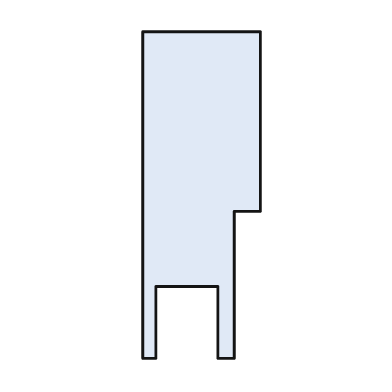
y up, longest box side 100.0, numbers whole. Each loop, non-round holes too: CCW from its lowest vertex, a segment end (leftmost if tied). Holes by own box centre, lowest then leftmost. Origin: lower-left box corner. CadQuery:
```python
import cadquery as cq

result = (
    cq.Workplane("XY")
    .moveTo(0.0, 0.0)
    .lineTo(4.0, 0.0)
    .lineTo(4.0, 22.0)
    .lineTo(23.0, 22.0)
    .lineTo(23.0, 0.0)
    .lineTo(28.0, 0.0)
    .lineTo(28.0, 45.0)
    .lineTo(36.0, 45.0)
    .lineTo(36.0, 100.0)
    .lineTo(0.0, 100.0)
    .close()
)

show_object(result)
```